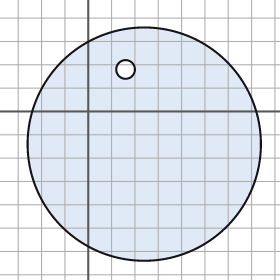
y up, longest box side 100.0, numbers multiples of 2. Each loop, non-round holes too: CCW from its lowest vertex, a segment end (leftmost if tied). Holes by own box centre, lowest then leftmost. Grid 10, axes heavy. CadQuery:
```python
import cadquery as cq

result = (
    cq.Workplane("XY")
    .moveTo(24.0, -14.0)
    .circle(50.0)
    .moveTo(16.0, 18.0)
    .circle(4.0)
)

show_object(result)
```